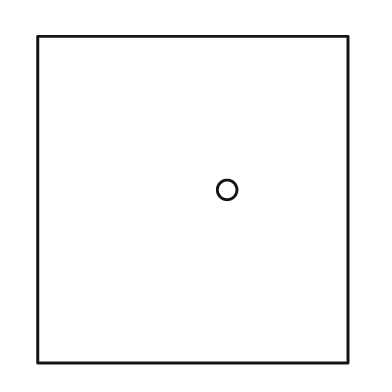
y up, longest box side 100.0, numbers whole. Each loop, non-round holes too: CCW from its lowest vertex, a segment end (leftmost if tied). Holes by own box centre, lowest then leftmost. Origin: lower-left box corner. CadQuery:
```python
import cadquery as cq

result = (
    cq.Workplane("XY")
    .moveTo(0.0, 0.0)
    .lineTo(95.0, 0.0)
    .lineTo(95.0, 100.0)
    .lineTo(0.0, 100.0)
    .close()
    .moveTo(58.0, 53.0)
    .circle(3.0)
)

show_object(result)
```